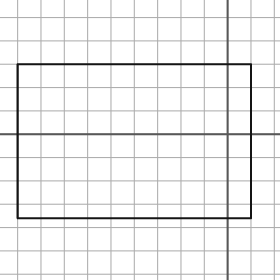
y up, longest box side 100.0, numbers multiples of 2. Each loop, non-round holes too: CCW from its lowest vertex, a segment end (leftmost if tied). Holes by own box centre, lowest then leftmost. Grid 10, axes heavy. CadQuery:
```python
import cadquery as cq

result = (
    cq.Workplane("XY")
    .moveTo(-90.0, -36.0)
    .lineTo(10.0, -36.0)
    .lineTo(10.0, 30.0)
    .lineTo(-90.0, 30.0)
    .close()
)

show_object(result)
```